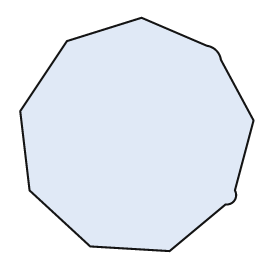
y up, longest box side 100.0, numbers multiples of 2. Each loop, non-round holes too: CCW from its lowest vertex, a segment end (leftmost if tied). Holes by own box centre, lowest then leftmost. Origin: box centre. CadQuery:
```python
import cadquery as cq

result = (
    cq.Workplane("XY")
    .moveTo(14.0, -50.0)
    .lineTo(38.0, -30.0)
    .threePointArc((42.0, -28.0), (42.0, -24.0))
    .lineTo(50.0, 6.0)
    .lineTo(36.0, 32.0)
    .threePointArc((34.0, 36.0), (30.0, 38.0))
    .lineTo(2.0, 50.0)
    .lineTo(-30.0, 40.0)
    .lineTo(-50.0, 10.0)
    .lineTo(-46.0, -24.0)
    .lineTo(-20.0, -48.0)
    .close()
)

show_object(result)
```